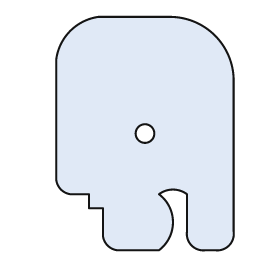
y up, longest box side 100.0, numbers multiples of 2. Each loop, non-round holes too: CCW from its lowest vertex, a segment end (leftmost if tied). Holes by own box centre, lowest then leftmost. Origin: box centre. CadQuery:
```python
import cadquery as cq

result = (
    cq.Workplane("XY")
    .moveTo(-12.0, -50.0)
    .lineTo(6.0, -50.0)
    .threePointArc((12.0, -38.0), (6.0, -26.0))
    .threePointArc((12.0, -24.0), (18.0, -26.0))
    .lineTo(18.0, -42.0)
    .threePointArc((20.0, -48.0), (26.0, -50.0))
    .lineTo(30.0, -50.0)
    .threePointArc((36.0, -48.0), (38.0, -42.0))
    .lineTo(38.0, 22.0)
    .threePointArc((30.0, 42.0), (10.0, 50.0))
    .lineTo(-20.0, 50.0)
    .threePointArc((-32.0, 44.0), (-38.0, 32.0))
    .lineTo(-38.0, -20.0)
    .threePointArc((-36.0, -24.0), (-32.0, -26.0))
    .lineTo(-24.0, -26.0)
    .lineTo(-24.0, -32.0)
    .lineTo(-18.0, -32.0)
    .lineTo(-18.0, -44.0)
    .threePointArc((-16.0, -48.0), (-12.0, -50.0))
    .close()
    .moveTo(0.0, 0.0)
    .circle(4.0)
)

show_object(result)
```